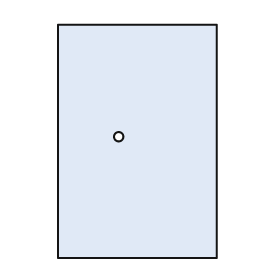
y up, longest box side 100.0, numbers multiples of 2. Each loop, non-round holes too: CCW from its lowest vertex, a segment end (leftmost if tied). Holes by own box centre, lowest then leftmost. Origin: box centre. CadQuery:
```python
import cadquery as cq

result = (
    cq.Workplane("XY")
    .moveTo(-34.0, -50.0)
    .lineTo(34.0, -50.0)
    .lineTo(34.0, 50.0)
    .lineTo(-34.0, 50.0)
    .close()
    .moveTo(-8.0, 2.0)
    .circle(2.0)
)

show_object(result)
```